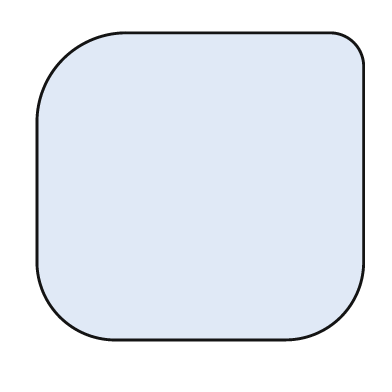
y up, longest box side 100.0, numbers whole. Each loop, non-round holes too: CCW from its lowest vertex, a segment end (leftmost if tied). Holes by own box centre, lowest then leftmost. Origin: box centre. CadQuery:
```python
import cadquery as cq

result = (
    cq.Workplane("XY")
    .moveTo(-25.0, -47.0)
    .lineTo(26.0, -47.0)
    .threePointArc((43.0, -40.0), (50.0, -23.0))
    .lineTo(50.0, 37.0)
    .threePointArc((47.0, 44.0), (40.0, 47.0))
    .lineTo(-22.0, 47.0)
    .threePointArc((-42.0, 39.0), (-50.0, 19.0))
    .lineTo(-50.0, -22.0)
    .threePointArc((-43.0, -40.0), (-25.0, -47.0))
    .close()
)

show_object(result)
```